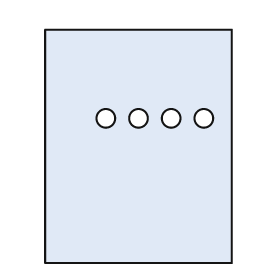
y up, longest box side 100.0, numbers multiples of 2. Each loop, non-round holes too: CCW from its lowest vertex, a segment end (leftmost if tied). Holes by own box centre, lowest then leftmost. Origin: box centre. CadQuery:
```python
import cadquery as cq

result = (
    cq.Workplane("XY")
    .moveTo(-40.0, -50.0)
    .lineTo(40.0, -50.0)
    .lineTo(40.0, 50.0)
    .lineTo(-40.0, 50.0)
    .close()
    .moveTo(-14.0, 12.0)
    .circle(4.0)
    .moveTo(0.0, 12.0)
    .circle(4.0)
    .moveTo(14.0, 12.0)
    .circle(4.0)
    .moveTo(28.0, 12.0)
    .circle(4.0)
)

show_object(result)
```